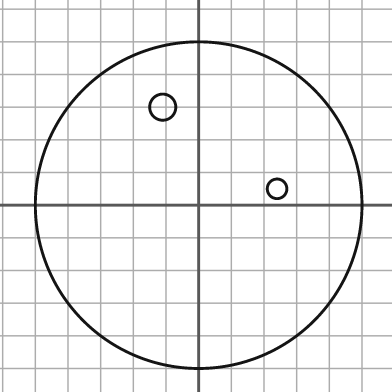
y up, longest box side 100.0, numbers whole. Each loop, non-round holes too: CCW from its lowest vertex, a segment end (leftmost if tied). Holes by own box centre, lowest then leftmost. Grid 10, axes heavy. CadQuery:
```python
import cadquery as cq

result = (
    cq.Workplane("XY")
    .moveTo(0.0, 0.0)
    .circle(50.0)
    .moveTo(24.0, 5.0)
    .circle(3.0)
    .moveTo(-11.0, 30.0)
    .circle(4.0)
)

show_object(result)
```